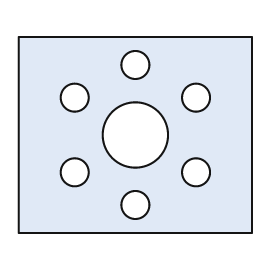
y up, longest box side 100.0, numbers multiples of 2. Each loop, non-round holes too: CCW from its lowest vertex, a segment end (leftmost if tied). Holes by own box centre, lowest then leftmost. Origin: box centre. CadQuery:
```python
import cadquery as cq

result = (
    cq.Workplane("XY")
    .moveTo(-50.0, -42.0)
    .lineTo(50.0, -42.0)
    .lineTo(50.0, 42.0)
    .lineTo(-50.0, 42.0)
    .close()
    .moveTo(0.0, -30.0)
    .circle(6.0)
    .moveTo(-26.0, -16.0)
    .circle(6.0)
    .moveTo(26.0, -16.0)
    .circle(6.0)
    .moveTo(0.0, 0.0)
    .circle(14.0)
    .moveTo(-26.0, 16.0)
    .circle(6.0)
    .moveTo(26.0, 16.0)
    .circle(6.0)
    .moveTo(0.0, 30.0)
    .circle(6.0)
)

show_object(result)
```